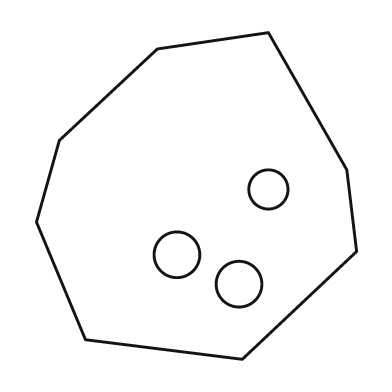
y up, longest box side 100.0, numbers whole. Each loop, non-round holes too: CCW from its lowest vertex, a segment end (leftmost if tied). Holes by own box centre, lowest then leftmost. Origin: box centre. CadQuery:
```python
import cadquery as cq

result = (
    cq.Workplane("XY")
    .moveTo(14.0, -50.0)
    .lineTo(49.0, -17.0)
    .lineTo(46.0, 8.0)
    .lineTo(22.0, 50.0)
    .lineTo(-12.0, 45.0)
    .lineTo(-42.0, 17.0)
    .lineTo(-49.0, -8.0)
    .lineTo(-34.0, -44.0)
    .close()
    .moveTo(13.0, -27.0)
    .circle(7.0)
    .moveTo(-6.0, -18.0)
    .circle(7.0)
    .moveTo(22.0, 2.0)
    .circle(6.0)
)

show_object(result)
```